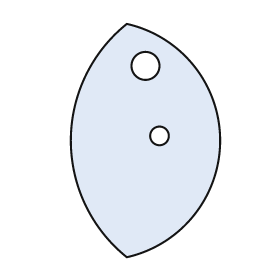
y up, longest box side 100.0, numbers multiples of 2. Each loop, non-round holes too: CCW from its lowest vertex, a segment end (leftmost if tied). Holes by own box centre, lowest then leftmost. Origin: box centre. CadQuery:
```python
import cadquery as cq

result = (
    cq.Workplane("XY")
    .moveTo(-8.0, -50.0)
    .threePointArc((32.0, 0.0), (-8.0, 50.0))
    .threePointArc((-32.0, 0.0), (-8.0, -50.0))
    .close()
    .moveTo(6.0, 2.0)
    .circle(4.0)
    .moveTo(0.0, 32.0)
    .circle(6.0)
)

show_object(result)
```